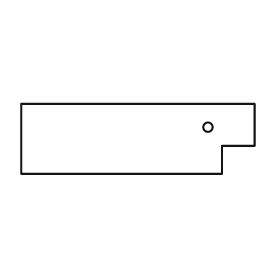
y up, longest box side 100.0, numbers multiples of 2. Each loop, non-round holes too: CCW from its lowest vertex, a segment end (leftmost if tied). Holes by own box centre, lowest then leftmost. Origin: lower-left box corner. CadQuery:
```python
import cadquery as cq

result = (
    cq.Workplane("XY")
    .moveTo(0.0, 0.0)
    .lineTo(86.0, 0.0)
    .lineTo(86.0, 12.0)
    .lineTo(100.0, 12.0)
    .lineTo(100.0, 30.0)
    .lineTo(0.0, 30.0)
    .close()
    .moveTo(80.0, 20.0)
    .circle(2.0)
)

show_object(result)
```